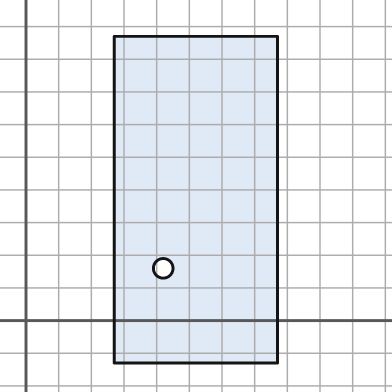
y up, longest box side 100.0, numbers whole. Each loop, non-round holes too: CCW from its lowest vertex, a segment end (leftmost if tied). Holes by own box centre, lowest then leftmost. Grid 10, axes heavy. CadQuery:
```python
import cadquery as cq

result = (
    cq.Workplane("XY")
    .moveTo(27.0, -13.0)
    .lineTo(77.0, -13.0)
    .lineTo(77.0, 87.0)
    .lineTo(27.0, 87.0)
    .close()
    .moveTo(42.0, 16.0)
    .circle(3.0)
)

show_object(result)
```